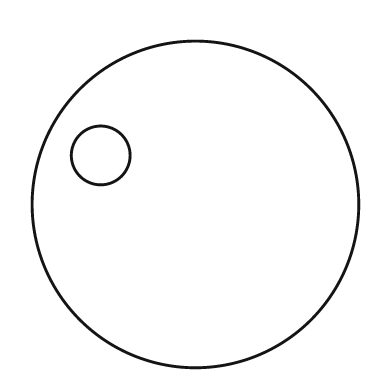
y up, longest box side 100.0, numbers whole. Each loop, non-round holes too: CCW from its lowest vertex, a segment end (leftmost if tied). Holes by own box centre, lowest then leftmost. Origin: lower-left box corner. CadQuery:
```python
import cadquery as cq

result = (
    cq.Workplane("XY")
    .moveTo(50.0, 50.0)
    .circle(50.0)
    .moveTo(21.0, 65.0)
    .circle(9.0)
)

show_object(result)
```